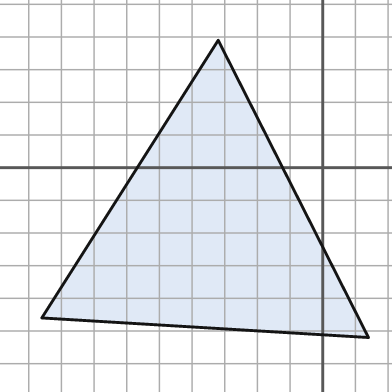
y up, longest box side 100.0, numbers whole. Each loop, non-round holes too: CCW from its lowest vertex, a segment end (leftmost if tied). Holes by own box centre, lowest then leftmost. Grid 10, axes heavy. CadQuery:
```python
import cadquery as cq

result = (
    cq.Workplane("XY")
    .moveTo(14.0, -52.0)
    .lineTo(-32.0, 39.0)
    .lineTo(-86.0, -46.0)
    .close()
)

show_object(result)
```